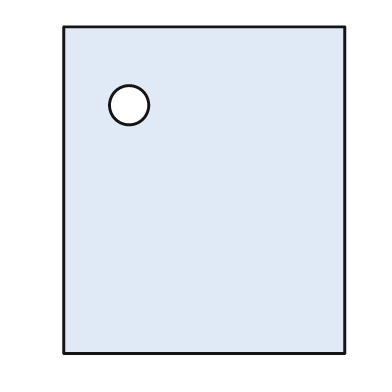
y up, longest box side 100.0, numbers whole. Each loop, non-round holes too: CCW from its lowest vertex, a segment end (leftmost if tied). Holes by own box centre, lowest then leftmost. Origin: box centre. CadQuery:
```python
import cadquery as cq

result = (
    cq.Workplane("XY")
    .moveTo(-43.0, -50.0)
    .lineTo(43.0, -50.0)
    .lineTo(43.0, 50.0)
    .lineTo(-43.0, 50.0)
    .close()
    .moveTo(-23.0, 26.0)
    .circle(6.0)
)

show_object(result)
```